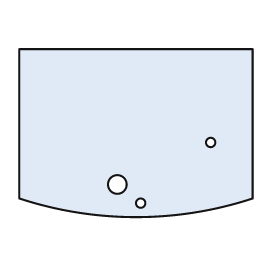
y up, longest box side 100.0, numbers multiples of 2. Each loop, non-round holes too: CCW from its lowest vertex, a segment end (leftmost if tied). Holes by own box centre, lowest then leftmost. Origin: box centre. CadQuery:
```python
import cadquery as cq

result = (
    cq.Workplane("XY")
    .moveTo(-50.0, -28.0)
    .threePointArc((0.0, -36.0), (50.0, -28.0))
    .lineTo(50.0, 36.0)
    .lineTo(-50.0, 36.0)
    .close()
    .moveTo(2.0, -30.0)
    .circle(2.0)
    .moveTo(-8.0, -22.0)
    .circle(4.0)
    .moveTo(32.0, -4.0)
    .circle(2.0)
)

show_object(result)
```